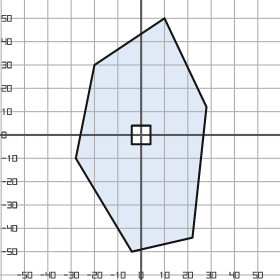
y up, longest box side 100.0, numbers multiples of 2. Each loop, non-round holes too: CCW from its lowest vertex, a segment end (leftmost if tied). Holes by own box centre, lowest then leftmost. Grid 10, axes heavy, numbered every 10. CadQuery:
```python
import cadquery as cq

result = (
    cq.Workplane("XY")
    .moveTo(-4.0, -50.0)
    .lineTo(22.0, -44.0)
    .lineTo(28.0, 12.0)
    .lineTo(10.0, 50.0)
    .lineTo(-20.0, 30.0)
    .lineTo(-28.0, -10.0)
    .close()
    .moveTo(-4.0, -4.0)
    .lineTo(4.0, -4.0)
    .lineTo(4.0, 4.0)
    .lineTo(-4.0, 4.0)
    .close()
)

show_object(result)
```